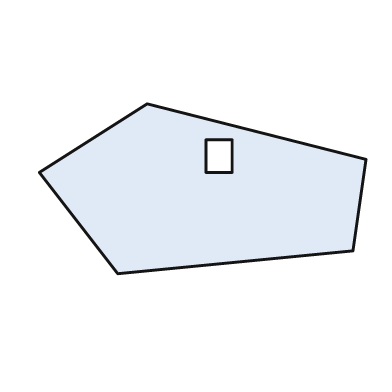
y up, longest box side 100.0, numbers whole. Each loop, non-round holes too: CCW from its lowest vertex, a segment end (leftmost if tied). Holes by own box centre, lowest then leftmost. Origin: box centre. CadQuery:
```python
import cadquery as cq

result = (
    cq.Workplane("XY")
    .moveTo(-26.0, -26.0)
    .lineTo(46.0, -19.0)
    .lineTo(50.0, 9.0)
    .lineTo(-17.0, 26.0)
    .lineTo(-50.0, 5.0)
    .close()
    .moveTo(1.0, 5.0)
    .lineTo(9.0, 5.0)
    .lineTo(9.0, 15.0)
    .lineTo(1.0, 15.0)
    .close()
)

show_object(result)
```